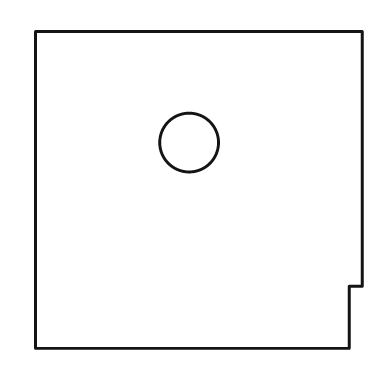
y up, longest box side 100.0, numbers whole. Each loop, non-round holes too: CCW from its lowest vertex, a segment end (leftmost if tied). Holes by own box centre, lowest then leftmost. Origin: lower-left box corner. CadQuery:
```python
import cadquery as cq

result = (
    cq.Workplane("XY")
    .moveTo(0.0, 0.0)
    .lineTo(96.0, 0.0)
    .lineTo(96.0, 19.0)
    .lineTo(100.0, 19.0)
    .lineTo(100.0, 97.0)
    .lineTo(0.0, 97.0)
    .close()
    .moveTo(47.0, 63.0)
    .circle(9.0)
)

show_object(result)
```